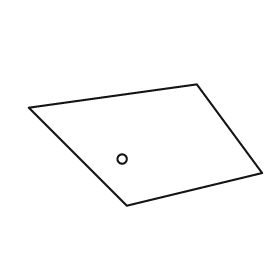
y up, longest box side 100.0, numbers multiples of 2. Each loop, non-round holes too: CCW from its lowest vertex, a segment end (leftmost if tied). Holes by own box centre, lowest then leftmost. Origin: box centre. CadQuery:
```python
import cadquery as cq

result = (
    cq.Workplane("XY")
    .moveTo(-8.0, -26.0)
    .lineTo(50.0, -12.0)
    .lineTo(22.0, 26.0)
    .lineTo(-50.0, 16.0)
    .close()
    .moveTo(-10.0, -6.0)
    .circle(2.0)
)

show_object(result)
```